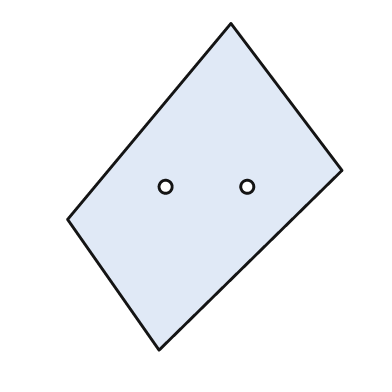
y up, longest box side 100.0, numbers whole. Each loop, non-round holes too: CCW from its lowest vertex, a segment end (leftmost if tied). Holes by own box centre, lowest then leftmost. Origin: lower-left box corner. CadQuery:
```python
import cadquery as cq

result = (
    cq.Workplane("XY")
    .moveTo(28.0, 0.0)
    .lineTo(84.0, 55.0)
    .lineTo(50.0, 100.0)
    .lineTo(0.0, 40.0)
    .close()
    .moveTo(30.0, 50.0)
    .circle(2.0)
    .moveTo(55.0, 50.0)
    .circle(2.0)
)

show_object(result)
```